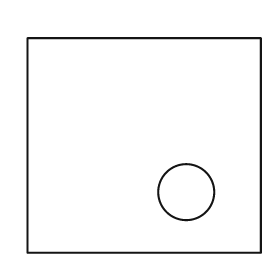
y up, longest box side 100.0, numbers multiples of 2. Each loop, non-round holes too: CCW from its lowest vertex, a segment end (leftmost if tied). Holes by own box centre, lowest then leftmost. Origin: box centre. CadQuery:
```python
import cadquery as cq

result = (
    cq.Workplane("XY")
    .moveTo(-50.0, -46.0)
    .lineTo(50.0, -46.0)
    .lineTo(50.0, 46.0)
    .lineTo(-50.0, 46.0)
    .close()
    .moveTo(18.0, -20.0)
    .circle(12.0)
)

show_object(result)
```